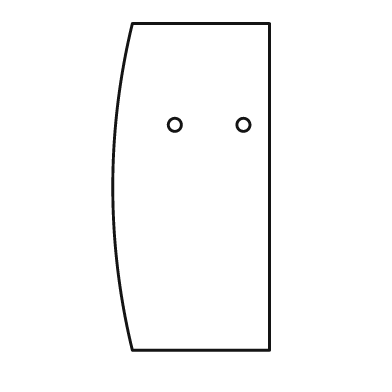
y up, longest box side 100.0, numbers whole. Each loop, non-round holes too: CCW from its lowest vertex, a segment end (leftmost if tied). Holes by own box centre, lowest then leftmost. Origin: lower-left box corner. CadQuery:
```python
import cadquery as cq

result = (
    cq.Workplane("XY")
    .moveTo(6.0, 0.0)
    .lineTo(48.0, 0.0)
    .lineTo(48.0, 100.0)
    .lineTo(6.0, 100.0)
    .threePointArc((0.0, 50.0), (6.0, 0.0))
    .close()
    .moveTo(19.0, 69.0)
    .circle(2.0)
    .moveTo(40.0, 69.0)
    .circle(2.0)
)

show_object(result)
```